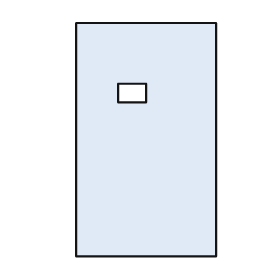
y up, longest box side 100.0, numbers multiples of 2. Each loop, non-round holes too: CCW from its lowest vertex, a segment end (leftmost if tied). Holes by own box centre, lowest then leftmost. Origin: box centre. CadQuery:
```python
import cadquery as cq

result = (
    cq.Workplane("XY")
    .moveTo(-30.0, -50.0)
    .lineTo(30.0, -50.0)
    .lineTo(30.0, 50.0)
    .lineTo(-30.0, 50.0)
    .close()
    .moveTo(-12.0, 16.0)
    .lineTo(0.0, 16.0)
    .lineTo(0.0, 24.0)
    .lineTo(-12.0, 24.0)
    .close()
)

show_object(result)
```